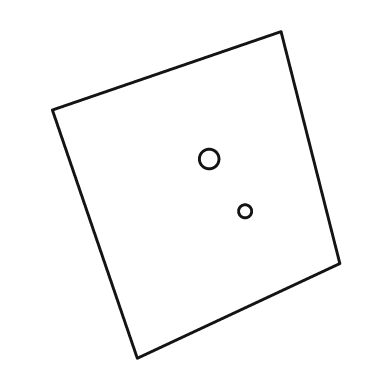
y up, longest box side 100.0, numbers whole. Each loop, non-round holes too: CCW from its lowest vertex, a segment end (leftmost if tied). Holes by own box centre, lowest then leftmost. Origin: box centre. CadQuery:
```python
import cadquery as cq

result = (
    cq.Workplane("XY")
    .moveTo(-18.0, -50.0)
    .lineTo(44.0, -21.0)
    .lineTo(26.0, 50.0)
    .lineTo(-44.0, 26.0)
    .close()
    .moveTo(15.0, -5.0)
    .circle(2.0)
    .moveTo(4.0, 11.0)
    .circle(3.0)
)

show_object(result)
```